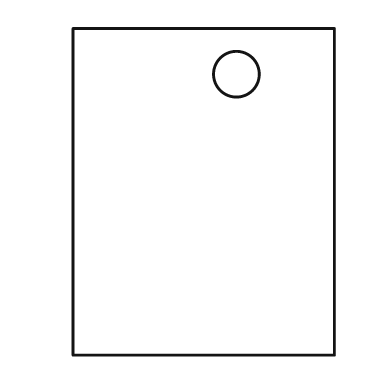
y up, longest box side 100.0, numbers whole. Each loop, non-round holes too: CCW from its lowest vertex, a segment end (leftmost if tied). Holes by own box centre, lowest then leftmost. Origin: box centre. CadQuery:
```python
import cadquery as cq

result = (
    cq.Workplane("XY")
    .moveTo(-40.0, -50.0)
    .lineTo(40.0, -50.0)
    .lineTo(40.0, 50.0)
    .lineTo(-40.0, 50.0)
    .close()
    .moveTo(10.0, 36.0)
    .circle(7.0)
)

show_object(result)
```